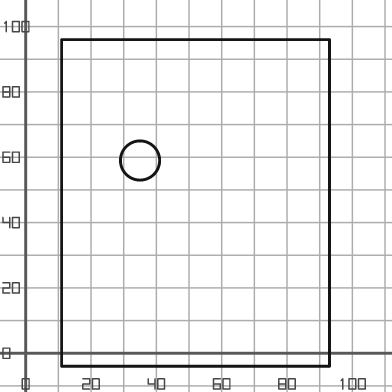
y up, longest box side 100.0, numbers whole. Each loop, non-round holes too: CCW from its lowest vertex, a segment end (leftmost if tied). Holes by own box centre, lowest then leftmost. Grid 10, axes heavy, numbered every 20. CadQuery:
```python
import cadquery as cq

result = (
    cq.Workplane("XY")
    .moveTo(11.0, -4.0)
    .lineTo(93.0, -4.0)
    .lineTo(93.0, 96.0)
    .lineTo(11.0, 96.0)
    .close()
    .moveTo(35.0, 59.0)
    .circle(6.0)
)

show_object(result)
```